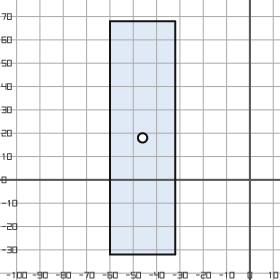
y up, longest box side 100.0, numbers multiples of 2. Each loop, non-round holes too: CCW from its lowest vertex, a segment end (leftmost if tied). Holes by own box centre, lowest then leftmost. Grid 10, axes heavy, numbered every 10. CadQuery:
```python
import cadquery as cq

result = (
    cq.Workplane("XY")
    .moveTo(-60.0, -32.0)
    .lineTo(-32.0, -32.0)
    .lineTo(-32.0, 68.0)
    .lineTo(-60.0, 68.0)
    .close()
    .moveTo(-46.0, 18.0)
    .circle(2.0)
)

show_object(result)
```